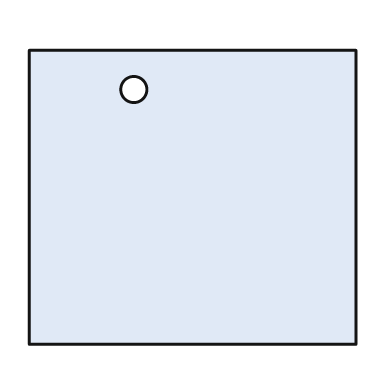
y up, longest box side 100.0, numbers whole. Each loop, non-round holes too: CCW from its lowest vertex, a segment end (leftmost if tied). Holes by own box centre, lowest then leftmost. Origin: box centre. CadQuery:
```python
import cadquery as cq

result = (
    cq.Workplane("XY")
    .moveTo(-50.0, -45.0)
    .lineTo(50.0, -45.0)
    .lineTo(50.0, 45.0)
    .lineTo(-50.0, 45.0)
    .close()
    .moveTo(-18.0, 33.0)
    .circle(4.0)
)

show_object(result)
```